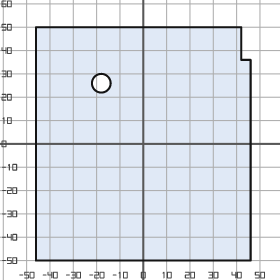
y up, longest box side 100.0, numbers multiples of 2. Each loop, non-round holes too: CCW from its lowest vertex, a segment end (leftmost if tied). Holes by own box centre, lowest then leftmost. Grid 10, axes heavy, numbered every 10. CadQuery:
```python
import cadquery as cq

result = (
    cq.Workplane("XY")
    .moveTo(-46.0, -50.0)
    .lineTo(46.0, -50.0)
    .lineTo(46.0, 36.0)
    .lineTo(42.0, 36.0)
    .lineTo(42.0, 50.0)
    .lineTo(-46.0, 50.0)
    .close()
    .moveTo(-18.0, 26.0)
    .circle(4.0)
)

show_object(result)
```